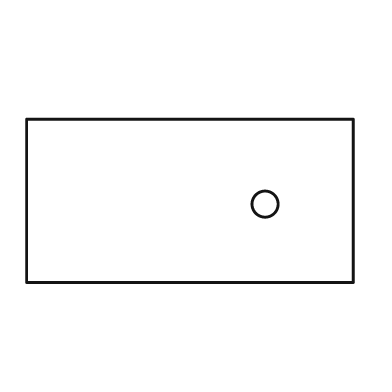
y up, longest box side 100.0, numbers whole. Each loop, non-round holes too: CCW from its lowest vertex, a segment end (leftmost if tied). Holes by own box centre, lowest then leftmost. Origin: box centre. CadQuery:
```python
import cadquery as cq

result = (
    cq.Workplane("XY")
    .moveTo(-50.0, -25.0)
    .lineTo(50.0, -25.0)
    .lineTo(50.0, 25.0)
    .lineTo(-50.0, 25.0)
    .close()
    .moveTo(23.0, -1.0)
    .circle(4.0)
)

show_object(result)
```